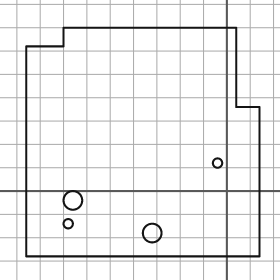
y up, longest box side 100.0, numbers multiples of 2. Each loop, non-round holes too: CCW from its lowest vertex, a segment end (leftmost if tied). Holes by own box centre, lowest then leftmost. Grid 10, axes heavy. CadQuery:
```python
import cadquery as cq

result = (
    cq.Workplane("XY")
    .moveTo(-86.0, -28.0)
    .lineTo(14.0, -28.0)
    .lineTo(14.0, 36.0)
    .lineTo(4.0, 36.0)
    .lineTo(4.0, 70.0)
    .lineTo(-70.0, 70.0)
    .lineTo(-70.0, 62.0)
    .lineTo(-86.0, 62.0)
    .close()
    .moveTo(-32.0, -18.0)
    .circle(4.0)
    .moveTo(-68.0, -14.0)
    .circle(2.0)
    .moveTo(-66.0, -4.0)
    .circle(4.0)
    .moveTo(-4.0, 12.0)
    .circle(2.0)
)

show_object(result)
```